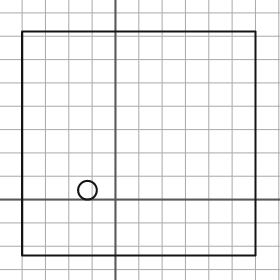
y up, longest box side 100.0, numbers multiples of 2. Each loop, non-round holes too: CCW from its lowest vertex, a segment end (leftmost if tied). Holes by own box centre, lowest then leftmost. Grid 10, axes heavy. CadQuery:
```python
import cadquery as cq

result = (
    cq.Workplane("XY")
    .moveTo(-40.0, -24.0)
    .lineTo(60.0, -24.0)
    .lineTo(60.0, 72.0)
    .lineTo(-40.0, 72.0)
    .close()
    .moveTo(-12.0, 4.0)
    .circle(4.0)
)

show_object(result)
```